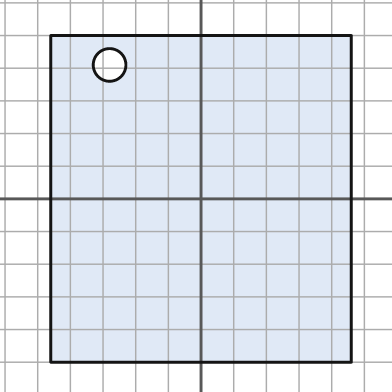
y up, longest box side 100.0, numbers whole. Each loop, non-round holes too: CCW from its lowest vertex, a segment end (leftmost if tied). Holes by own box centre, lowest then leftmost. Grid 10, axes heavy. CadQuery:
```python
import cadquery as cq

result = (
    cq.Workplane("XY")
    .moveTo(-46.0, -50.0)
    .lineTo(46.0, -50.0)
    .lineTo(46.0, 50.0)
    .lineTo(-46.0, 50.0)
    .close()
    .moveTo(-28.0, 41.0)
    .circle(5.0)
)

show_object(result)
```